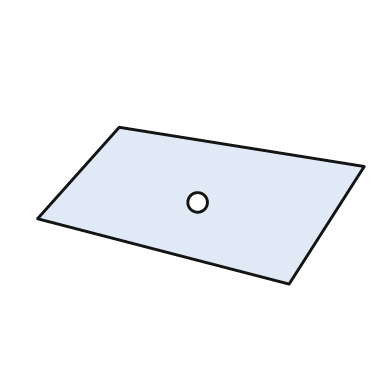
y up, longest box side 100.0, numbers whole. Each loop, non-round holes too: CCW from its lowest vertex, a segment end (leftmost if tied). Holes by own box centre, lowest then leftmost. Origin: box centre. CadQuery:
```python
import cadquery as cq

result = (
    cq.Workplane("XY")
    .moveTo(27.0, -24.0)
    .lineTo(50.0, 12.0)
    .lineTo(-25.0, 24.0)
    .lineTo(-50.0, -4.0)
    .close()
    .moveTo(-1.0, 1.0)
    .circle(3.0)
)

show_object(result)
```